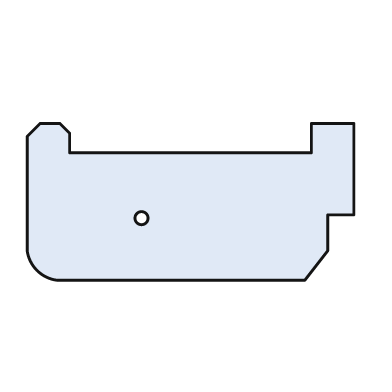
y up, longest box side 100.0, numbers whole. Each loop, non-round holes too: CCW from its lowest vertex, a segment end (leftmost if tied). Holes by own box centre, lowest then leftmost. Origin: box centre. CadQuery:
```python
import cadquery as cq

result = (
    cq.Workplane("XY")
    .moveTo(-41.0, -24.0)
    .lineTo(35.0, -24.0)
    .lineTo(42.0, -15.0)
    .lineTo(42.0, -4.0)
    .lineTo(50.0, -4.0)
    .lineTo(50.0, 24.0)
    .lineTo(37.0, 24.0)
    .lineTo(37.0, 15.0)
    .lineTo(-37.0, 15.0)
    .lineTo(-37.0, 21.0)
    .lineTo(-40.0, 24.0)
    .lineTo(-46.0, 24.0)
    .lineTo(-50.0, 20.0)
    .lineTo(-50.0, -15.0)
    .threePointArc((-47.0, -21.0), (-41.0, -24.0))
    .close()
    .moveTo(-15.0, -5.0)
    .circle(2.0)
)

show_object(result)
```